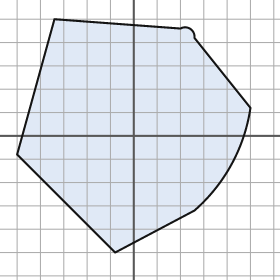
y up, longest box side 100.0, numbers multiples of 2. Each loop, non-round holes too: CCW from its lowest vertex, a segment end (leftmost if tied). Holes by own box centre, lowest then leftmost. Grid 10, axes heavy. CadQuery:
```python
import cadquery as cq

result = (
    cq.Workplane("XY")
    .moveTo(-8.0, -50.0)
    .lineTo(26.0, -32.0)
    .threePointArc((42.0, -12.0), (50.0, 12.0))
    .lineTo(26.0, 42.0)
    .threePointArc((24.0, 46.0), (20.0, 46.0))
    .lineTo(-34.0, 50.0)
    .lineTo(-50.0, -8.0)
    .close()
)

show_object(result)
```